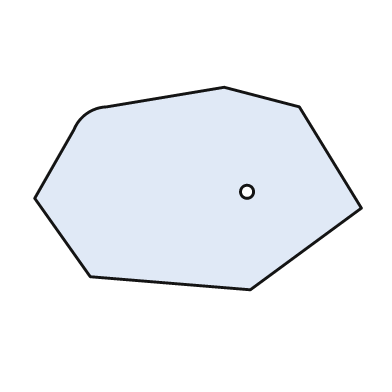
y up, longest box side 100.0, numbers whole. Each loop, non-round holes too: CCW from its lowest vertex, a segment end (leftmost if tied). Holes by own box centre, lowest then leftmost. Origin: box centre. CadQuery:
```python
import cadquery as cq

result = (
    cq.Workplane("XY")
    .moveTo(16.0, -31.0)
    .lineTo(50.0, -6.0)
    .lineTo(31.0, 25.0)
    .lineTo(8.0, 31.0)
    .lineTo(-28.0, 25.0)
    .threePointArc((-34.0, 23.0), (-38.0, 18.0))
    .lineTo(-50.0, -3.0)
    .lineTo(-33.0, -27.0)
    .close()
    .moveTo(15.0, -1.0)
    .circle(2.0)
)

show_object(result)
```